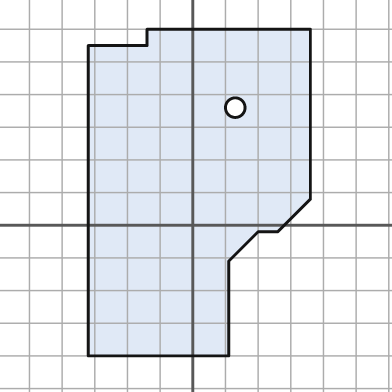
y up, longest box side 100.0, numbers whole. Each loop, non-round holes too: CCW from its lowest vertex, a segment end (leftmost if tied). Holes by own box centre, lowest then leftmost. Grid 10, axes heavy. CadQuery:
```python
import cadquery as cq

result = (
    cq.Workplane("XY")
    .moveTo(-32.0, -40.0)
    .lineTo(11.0, -40.0)
    .lineTo(11.0, -11.0)
    .lineTo(20.0, -2.0)
    .lineTo(26.0, -2.0)
    .lineTo(36.0, 8.0)
    .lineTo(36.0, 60.0)
    .lineTo(-14.0, 60.0)
    .lineTo(-14.0, 55.0)
    .lineTo(-32.0, 55.0)
    .close()
    .moveTo(13.0, 36.0)
    .circle(3.0)
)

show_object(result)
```